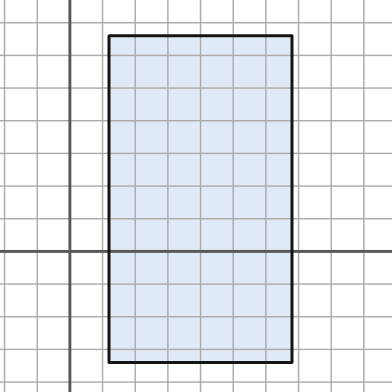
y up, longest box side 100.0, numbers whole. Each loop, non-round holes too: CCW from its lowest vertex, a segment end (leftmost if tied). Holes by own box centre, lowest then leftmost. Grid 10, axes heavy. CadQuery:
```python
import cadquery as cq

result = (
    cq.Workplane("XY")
    .moveTo(12.0, -34.0)
    .lineTo(68.0, -34.0)
    .lineTo(68.0, 66.0)
    .lineTo(12.0, 66.0)
    .close()
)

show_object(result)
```